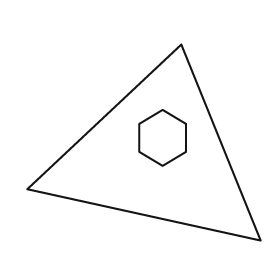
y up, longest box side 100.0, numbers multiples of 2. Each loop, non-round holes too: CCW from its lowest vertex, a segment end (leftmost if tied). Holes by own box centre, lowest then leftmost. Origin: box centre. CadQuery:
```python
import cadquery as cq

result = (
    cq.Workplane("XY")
    .moveTo(50.0, -42.0)
    .lineTo(16.0, 42.0)
    .lineTo(-50.0, -20.0)
    .close()
    .moveTo(8.0, -10.0)
    .lineTo(18.0, -4.0)
    .lineTo(18.0, 8.0)
    .lineTo(8.0, 14.0)
    .lineTo(-2.0, 8.0)
    .lineTo(-2.0, -4.0)
    .close()
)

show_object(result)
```